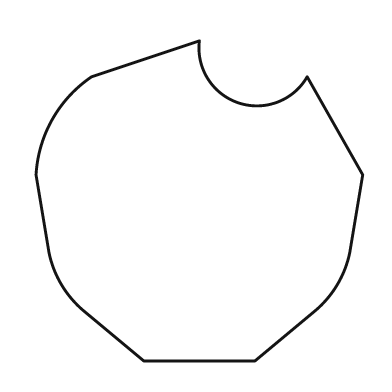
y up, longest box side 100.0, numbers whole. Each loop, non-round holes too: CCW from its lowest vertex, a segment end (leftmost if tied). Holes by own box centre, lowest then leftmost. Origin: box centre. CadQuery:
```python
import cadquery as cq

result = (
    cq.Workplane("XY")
    .moveTo(-17.0, -49.0)
    .lineTo(17.0, -49.0)
    .lineTo(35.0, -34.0)
    .threePointArc((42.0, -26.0), (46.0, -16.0))
    .lineTo(50.0, 8.0)
    .lineTo(33.0, 38.0)
    .threePointArc((12.0, 30.0), (0.0, 49.0))
    .lineTo(-33.0, 38.0)
    .threePointArc((-45.0, 25.0), (-50.0, 8.0))
    .lineTo(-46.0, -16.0)
    .threePointArc((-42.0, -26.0), (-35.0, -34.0))
    .close()
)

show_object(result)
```